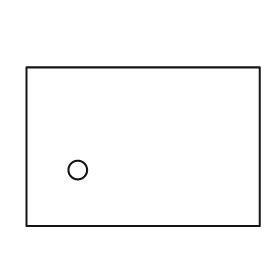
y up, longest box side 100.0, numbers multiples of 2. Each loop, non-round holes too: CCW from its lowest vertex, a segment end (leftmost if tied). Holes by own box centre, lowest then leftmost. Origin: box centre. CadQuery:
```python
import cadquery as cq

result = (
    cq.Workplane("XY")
    .moveTo(-50.0, -34.0)
    .lineTo(50.0, -34.0)
    .lineTo(50.0, 34.0)
    .lineTo(-50.0, 34.0)
    .close()
    .moveTo(-28.0, -10.0)
    .circle(4.0)
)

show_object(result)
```